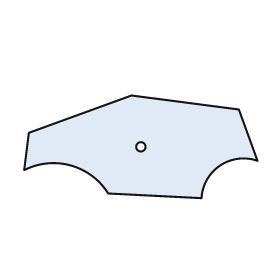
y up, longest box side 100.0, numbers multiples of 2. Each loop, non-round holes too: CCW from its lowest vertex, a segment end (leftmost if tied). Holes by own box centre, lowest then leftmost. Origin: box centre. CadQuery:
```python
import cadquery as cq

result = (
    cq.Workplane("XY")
    .moveTo(26.0, -22.0)
    .threePointArc((34.0, -8.0), (50.0, -6.0))
    .lineTo(42.0, 16.0)
    .lineTo(-4.0, 22.0)
    .lineTo(-48.0, 6.0)
    .lineTo(-50.0, -10.0)
    .threePointArc((-30.0, -8.0), (-14.0, -20.0))
    .close()
    .moveTo(0.0, 0.0)
    .circle(2.0)
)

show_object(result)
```